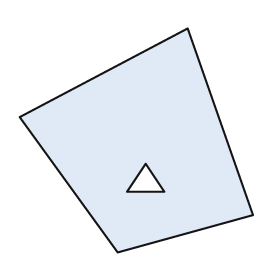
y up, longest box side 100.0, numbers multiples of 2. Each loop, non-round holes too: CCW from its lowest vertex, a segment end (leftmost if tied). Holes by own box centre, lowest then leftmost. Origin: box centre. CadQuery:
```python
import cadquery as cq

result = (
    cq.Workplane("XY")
    .moveTo(-8.0, -48.0)
    .lineTo(50.0, -32.0)
    .lineTo(22.0, 48.0)
    .lineTo(-50.0, 10.0)
    .close()
    .moveTo(-4.0, -22.0)
    .lineTo(12.0, -22.0)
    .lineTo(4.0, -10.0)
    .close()
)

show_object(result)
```